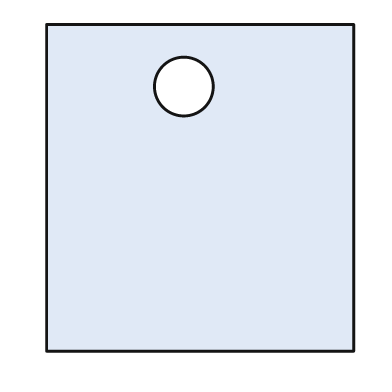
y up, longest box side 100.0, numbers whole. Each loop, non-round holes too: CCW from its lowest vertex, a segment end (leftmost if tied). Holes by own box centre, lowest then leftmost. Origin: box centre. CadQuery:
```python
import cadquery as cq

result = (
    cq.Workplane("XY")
    .moveTo(-47.0, -50.0)
    .lineTo(47.0, -50.0)
    .lineTo(47.0, 50.0)
    .lineTo(-47.0, 50.0)
    .close()
    .moveTo(-5.0, 31.0)
    .circle(9.0)
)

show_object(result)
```